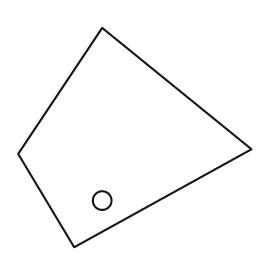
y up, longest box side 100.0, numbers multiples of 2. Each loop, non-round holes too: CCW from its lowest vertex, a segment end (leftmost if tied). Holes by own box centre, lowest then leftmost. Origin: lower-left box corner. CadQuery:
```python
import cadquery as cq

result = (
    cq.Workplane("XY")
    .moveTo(24.0, 0.0)
    .lineTo(100.0, 42.0)
    .lineTo(36.0, 94.0)
    .lineTo(0.0, 40.0)
    .close()
    .moveTo(36.0, 20.0)
    .circle(4.0)
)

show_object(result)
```